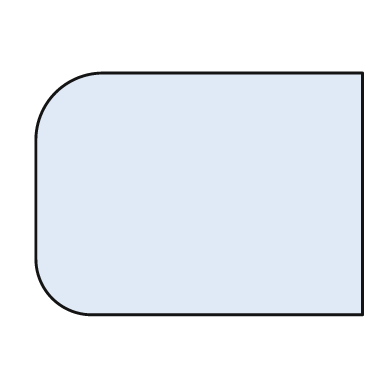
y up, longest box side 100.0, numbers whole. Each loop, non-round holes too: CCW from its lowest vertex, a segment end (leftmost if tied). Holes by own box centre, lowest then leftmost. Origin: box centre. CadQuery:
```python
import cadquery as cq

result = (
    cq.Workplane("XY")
    .moveTo(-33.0, -37.0)
    .lineTo(50.0, -37.0)
    .lineTo(50.0, 37.0)
    .lineTo(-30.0, 37.0)
    .threePointArc((-44.0, 31.0), (-50.0, 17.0))
    .lineTo(-50.0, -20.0)
    .threePointArc((-45.0, -32.0), (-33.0, -37.0))
    .close()
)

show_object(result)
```